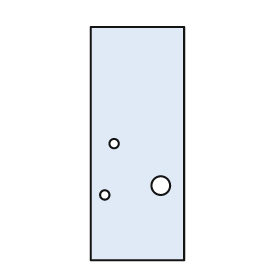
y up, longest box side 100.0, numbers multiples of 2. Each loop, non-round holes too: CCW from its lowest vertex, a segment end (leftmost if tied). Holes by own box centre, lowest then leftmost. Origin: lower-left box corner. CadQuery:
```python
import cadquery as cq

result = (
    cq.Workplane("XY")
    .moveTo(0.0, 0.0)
    .lineTo(40.0, 0.0)
    .lineTo(40.0, 100.0)
    .lineTo(0.0, 100.0)
    .close()
    .moveTo(6.0, 28.0)
    .circle(2.0)
    .moveTo(30.0, 32.0)
    .circle(4.0)
    .moveTo(10.0, 50.0)
    .circle(2.0)
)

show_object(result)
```